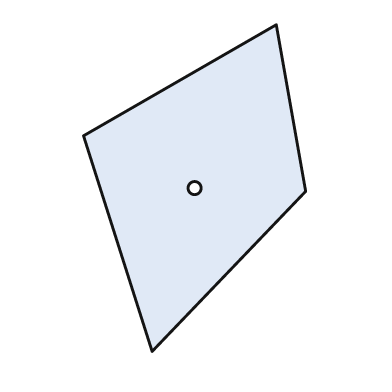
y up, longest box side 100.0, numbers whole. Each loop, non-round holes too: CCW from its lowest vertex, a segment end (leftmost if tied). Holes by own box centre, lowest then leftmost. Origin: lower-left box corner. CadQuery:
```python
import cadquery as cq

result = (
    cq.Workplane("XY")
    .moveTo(21.0, 0.0)
    .lineTo(68.0, 49.0)
    .lineTo(59.0, 100.0)
    .lineTo(0.0, 66.0)
    .close()
    .moveTo(34.0, 50.0)
    .circle(2.0)
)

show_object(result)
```